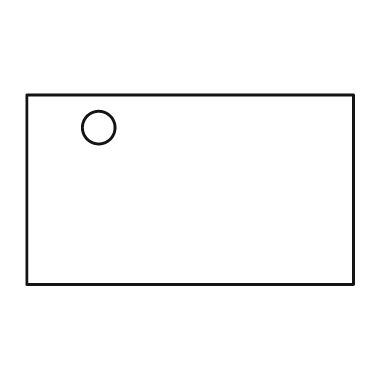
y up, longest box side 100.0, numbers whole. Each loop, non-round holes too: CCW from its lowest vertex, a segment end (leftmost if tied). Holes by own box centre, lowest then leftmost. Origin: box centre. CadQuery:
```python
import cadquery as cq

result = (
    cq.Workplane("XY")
    .moveTo(-50.0, -29.0)
    .lineTo(50.0, -29.0)
    .lineTo(50.0, 29.0)
    .lineTo(-50.0, 29.0)
    .close()
    .moveTo(-28.0, 19.0)
    .circle(5.0)
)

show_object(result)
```